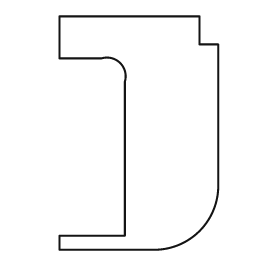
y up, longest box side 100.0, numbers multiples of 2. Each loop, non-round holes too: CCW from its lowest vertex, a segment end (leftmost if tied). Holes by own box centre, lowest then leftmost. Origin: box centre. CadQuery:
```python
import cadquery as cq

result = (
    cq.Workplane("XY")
    .moveTo(-34.0, -50.0)
    .lineTo(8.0, -50.0)
    .threePointArc((26.0, -42.0), (34.0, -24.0))
    .lineTo(34.0, 38.0)
    .lineTo(26.0, 38.0)
    .lineTo(26.0, 50.0)
    .lineTo(-34.0, 50.0)
    .lineTo(-34.0, 32.0)
    .lineTo(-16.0, 32.0)
    .threePointArc((-8.0, 30.0), (-6.0, 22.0))
    .lineTo(-6.0, -44.0)
    .lineTo(-34.0, -44.0)
    .close()
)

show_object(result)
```